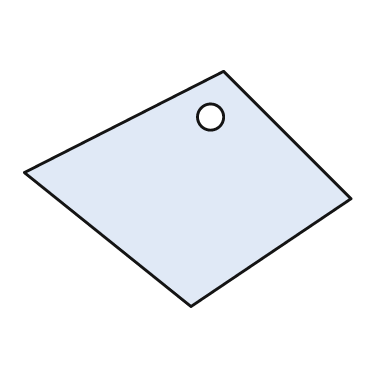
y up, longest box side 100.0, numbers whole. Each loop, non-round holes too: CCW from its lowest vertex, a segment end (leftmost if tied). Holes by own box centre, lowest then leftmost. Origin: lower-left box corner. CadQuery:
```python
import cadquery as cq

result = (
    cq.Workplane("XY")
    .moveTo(51.0, 0.0)
    .lineTo(100.0, 33.0)
    .lineTo(61.0, 72.0)
    .lineTo(0.0, 41.0)
    .close()
    .moveTo(57.0, 58.0)
    .circle(4.0)
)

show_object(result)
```